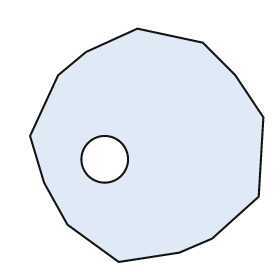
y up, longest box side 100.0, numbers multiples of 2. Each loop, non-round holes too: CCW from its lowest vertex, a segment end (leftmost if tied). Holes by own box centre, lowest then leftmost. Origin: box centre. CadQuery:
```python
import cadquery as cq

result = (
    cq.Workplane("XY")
    .moveTo(-12.0, -50.0)
    .lineTo(14.0, -46.0)
    .lineTo(28.0, -40.0)
    .lineTo(48.0, -22.0)
    .lineTo(50.0, 12.0)
    .lineTo(38.0, 30.0)
    .lineTo(24.0, 44.0)
    .lineTo(-4.0, 50.0)
    .lineTo(-26.0, 40.0)
    .lineTo(-38.0, 30.0)
    .lineTo(-50.0, 4.0)
    .lineTo(-44.0, -16.0)
    .lineTo(-34.0, -34.0)
    .close()
    .moveTo(-18.0, -6.0)
    .circle(10.0)
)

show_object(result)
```